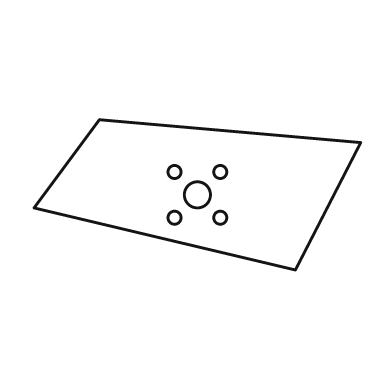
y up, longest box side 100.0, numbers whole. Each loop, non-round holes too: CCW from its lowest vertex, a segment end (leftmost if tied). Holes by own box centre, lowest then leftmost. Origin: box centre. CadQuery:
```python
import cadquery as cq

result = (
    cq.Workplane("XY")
    .moveTo(30.0, -23.0)
    .lineTo(50.0, 16.0)
    .lineTo(-30.0, 23.0)
    .lineTo(-50.0, -4.0)
    .close()
    .moveTo(-7.0, -7.0)
    .circle(2.0)
    .moveTo(7.0, -7.0)
    .circle(2.0)
    .moveTo(0.0, 0.0)
    .circle(4.0)
    .moveTo(-7.0, 7.0)
    .circle(2.0)
    .moveTo(7.0, 7.0)
    .circle(2.0)
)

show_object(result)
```